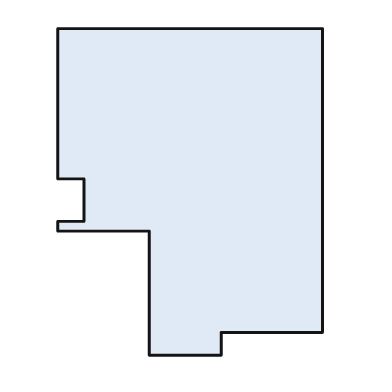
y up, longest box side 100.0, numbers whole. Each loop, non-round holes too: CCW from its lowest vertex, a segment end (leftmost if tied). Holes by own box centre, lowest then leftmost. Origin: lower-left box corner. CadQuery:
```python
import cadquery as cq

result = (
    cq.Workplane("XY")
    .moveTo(28.0, 0.0)
    .lineTo(50.0, 0.0)
    .lineTo(50.0, 7.0)
    .lineTo(81.0, 7.0)
    .lineTo(81.0, 100.0)
    .lineTo(0.0, 100.0)
    .lineTo(0.0, 54.0)
    .lineTo(8.0, 54.0)
    .lineTo(8.0, 41.0)
    .lineTo(0.0, 41.0)
    .lineTo(0.0, 38.0)
    .lineTo(28.0, 38.0)
    .close()
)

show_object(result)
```